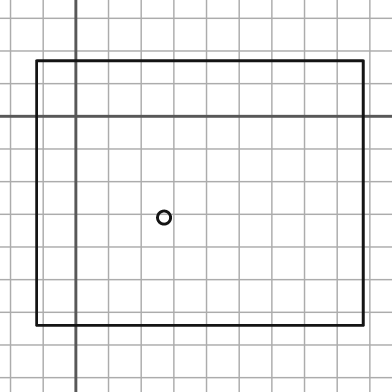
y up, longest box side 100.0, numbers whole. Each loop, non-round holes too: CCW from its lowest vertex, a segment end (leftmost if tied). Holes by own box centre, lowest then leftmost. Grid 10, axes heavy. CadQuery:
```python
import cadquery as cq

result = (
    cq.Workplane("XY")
    .moveTo(-12.0, -64.0)
    .lineTo(88.0, -64.0)
    .lineTo(88.0, 17.0)
    .lineTo(-12.0, 17.0)
    .close()
    .moveTo(27.0, -31.0)
    .circle(2.0)
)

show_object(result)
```